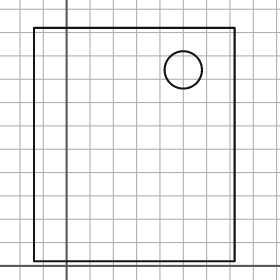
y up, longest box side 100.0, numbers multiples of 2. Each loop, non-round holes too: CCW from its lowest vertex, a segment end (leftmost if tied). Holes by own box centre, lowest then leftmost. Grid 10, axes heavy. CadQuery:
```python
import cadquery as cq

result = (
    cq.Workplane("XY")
    .moveTo(-14.0, 2.0)
    .lineTo(72.0, 2.0)
    .lineTo(72.0, 102.0)
    .lineTo(-14.0, 102.0)
    .close()
    .moveTo(50.0, 84.0)
    .circle(8.0)
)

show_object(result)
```